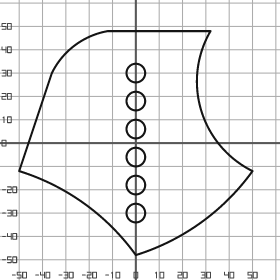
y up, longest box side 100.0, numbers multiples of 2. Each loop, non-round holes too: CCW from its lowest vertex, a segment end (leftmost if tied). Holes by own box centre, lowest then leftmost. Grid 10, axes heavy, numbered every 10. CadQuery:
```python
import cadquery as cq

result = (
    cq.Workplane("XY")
    .moveTo(0.0, -48.0)
    .threePointArc((28.0, -34.0), (50.0, -12.0))
    .threePointArc((28.0, 14.0), (32.0, 48.0))
    .lineTo(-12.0, 48.0)
    .threePointArc((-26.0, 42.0), (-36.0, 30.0))
    .lineTo(-50.0, -12.0)
    .threePointArc((-22.0, -26.0), (0.0, -48.0))
    .close()
    .moveTo(0.0, -30.0)
    .circle(4.0)
    .moveTo(0.0, -18.0)
    .circle(4.0)
    .moveTo(0.0, -6.0)
    .circle(4.0)
    .moveTo(0.0, 6.0)
    .circle(4.0)
    .moveTo(0.0, 18.0)
    .circle(4.0)
    .moveTo(0.0, 30.0)
    .circle(4.0)
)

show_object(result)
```